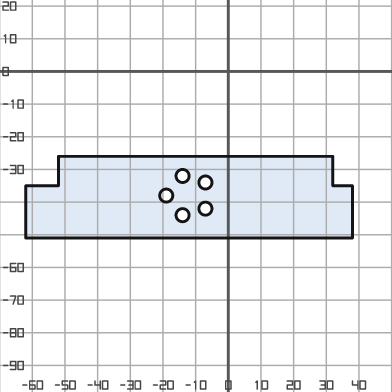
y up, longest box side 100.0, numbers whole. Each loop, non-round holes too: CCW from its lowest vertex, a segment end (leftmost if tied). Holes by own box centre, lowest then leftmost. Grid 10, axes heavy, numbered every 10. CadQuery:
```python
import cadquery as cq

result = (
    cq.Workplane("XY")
    .moveTo(-62.0, -51.0)
    .lineTo(38.0, -51.0)
    .lineTo(38.0, -35.0)
    .lineTo(32.0, -35.0)
    .lineTo(32.0, -26.0)
    .lineTo(-52.0, -26.0)
    .lineTo(-52.0, -35.0)
    .lineTo(-62.0, -35.0)
    .close()
    .moveTo(-14.0, -44.0)
    .circle(2.0)
    .moveTo(-7.0, -42.0)
    .circle(2.0)
    .moveTo(-19.0, -38.0)
    .circle(2.0)
    .moveTo(-7.0, -34.0)
    .circle(2.0)
    .moveTo(-14.0, -32.0)
    .circle(2.0)
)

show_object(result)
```